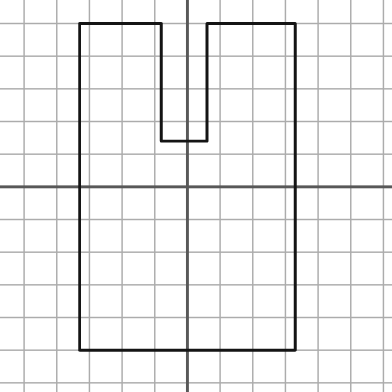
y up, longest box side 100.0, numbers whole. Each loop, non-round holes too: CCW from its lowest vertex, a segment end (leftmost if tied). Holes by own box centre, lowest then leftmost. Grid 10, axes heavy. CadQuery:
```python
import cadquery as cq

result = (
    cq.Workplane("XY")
    .moveTo(-33.0, -50.0)
    .lineTo(33.0, -50.0)
    .lineTo(33.0, 50.0)
    .lineTo(6.0, 50.0)
    .lineTo(6.0, 14.0)
    .lineTo(-8.0, 14.0)
    .lineTo(-8.0, 50.0)
    .lineTo(-33.0, 50.0)
    .close()
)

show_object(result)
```